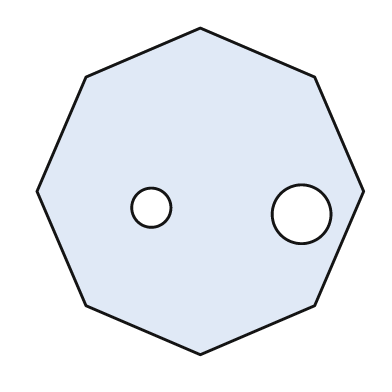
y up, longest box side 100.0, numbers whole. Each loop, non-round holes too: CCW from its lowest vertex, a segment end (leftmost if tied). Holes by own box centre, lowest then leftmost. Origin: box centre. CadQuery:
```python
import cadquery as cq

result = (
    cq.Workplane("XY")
    .moveTo(0.0, -50.0)
    .lineTo(35.0, -35.0)
    .lineTo(50.0, 0.0)
    .lineTo(35.0, 35.0)
    .lineTo(0.0, 50.0)
    .lineTo(-35.0, 35.0)
    .lineTo(-50.0, 0.0)
    .lineTo(-35.0, -35.0)
    .close()
    .moveTo(31.0, -7.0)
    .circle(9.0)
    .moveTo(-15.0, -5.0)
    .circle(6.0)
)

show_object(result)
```